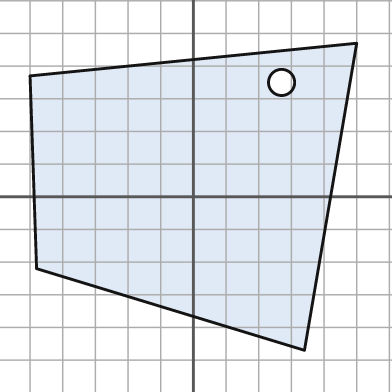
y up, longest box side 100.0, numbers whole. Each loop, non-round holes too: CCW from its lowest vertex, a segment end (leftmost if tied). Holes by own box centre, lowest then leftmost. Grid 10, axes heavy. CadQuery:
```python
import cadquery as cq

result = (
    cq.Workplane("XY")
    .moveTo(34.0, -47.0)
    .lineTo(50.0, 47.0)
    .lineTo(-50.0, 37.0)
    .lineTo(-48.0, -22.0)
    .close()
    .moveTo(27.0, 35.0)
    .circle(4.0)
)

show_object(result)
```